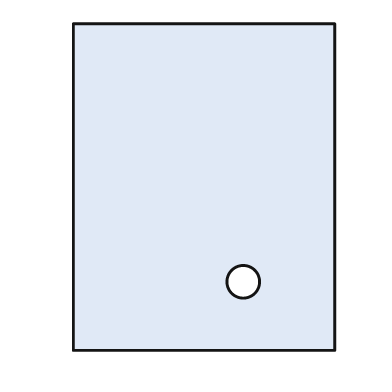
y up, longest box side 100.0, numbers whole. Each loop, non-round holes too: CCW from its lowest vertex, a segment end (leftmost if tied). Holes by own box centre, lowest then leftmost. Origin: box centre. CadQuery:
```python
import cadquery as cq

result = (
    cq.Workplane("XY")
    .moveTo(-40.0, -50.0)
    .lineTo(40.0, -50.0)
    .lineTo(40.0, 50.0)
    .lineTo(-40.0, 50.0)
    .close()
    .moveTo(12.0, -29.0)
    .circle(5.0)
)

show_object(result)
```